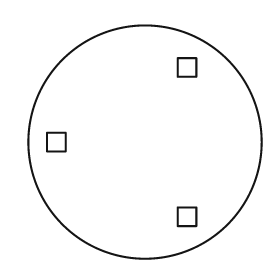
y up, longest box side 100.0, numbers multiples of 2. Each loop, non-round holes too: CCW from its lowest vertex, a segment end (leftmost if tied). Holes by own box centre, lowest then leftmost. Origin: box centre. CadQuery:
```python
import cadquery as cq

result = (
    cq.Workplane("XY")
    .moveTo(0.0, 0.0)
    .circle(50.0)
    .moveTo(14.0, -36.0)
    .lineTo(22.0, -36.0)
    .lineTo(22.0, -28.0)
    .lineTo(14.0, -28.0)
    .close()
    .moveTo(-42.0, -4.0)
    .lineTo(-34.0, -4.0)
    .lineTo(-34.0, 4.0)
    .lineTo(-42.0, 4.0)
    .close()
    .moveTo(14.0, 28.0)
    .lineTo(22.0, 28.0)
    .lineTo(22.0, 36.0)
    .lineTo(14.0, 36.0)
    .close()
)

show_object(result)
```